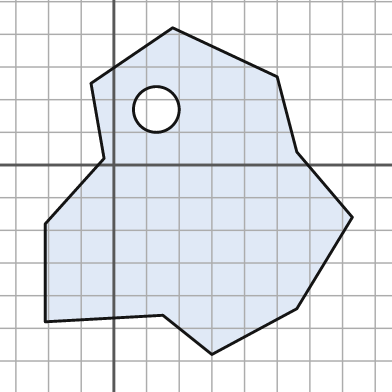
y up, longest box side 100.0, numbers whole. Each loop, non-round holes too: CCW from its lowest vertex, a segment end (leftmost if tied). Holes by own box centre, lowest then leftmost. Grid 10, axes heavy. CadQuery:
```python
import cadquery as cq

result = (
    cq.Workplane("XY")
    .moveTo(30.0, -58.0)
    .lineTo(56.0, -44.0)
    .lineTo(73.0, -16.0)
    .lineTo(56.0, 4.0)
    .lineTo(50.0, 27.0)
    .lineTo(18.0, 42.0)
    .lineTo(-7.0, 25.0)
    .lineTo(-3.0, 2.0)
    .lineTo(-21.0, -18.0)
    .lineTo(-21.0, -48.0)
    .lineTo(15.0, -46.0)
    .close()
    .moveTo(13.0, 17.0)
    .circle(7.0)
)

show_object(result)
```